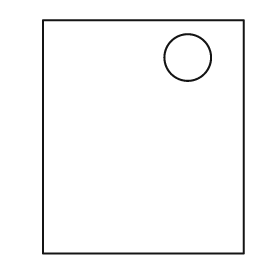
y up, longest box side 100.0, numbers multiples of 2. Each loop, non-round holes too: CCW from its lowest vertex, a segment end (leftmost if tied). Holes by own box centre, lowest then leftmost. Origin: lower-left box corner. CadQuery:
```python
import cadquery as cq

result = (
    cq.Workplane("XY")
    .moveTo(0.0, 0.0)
    .lineTo(86.0, 0.0)
    .lineTo(86.0, 100.0)
    .lineTo(0.0, 100.0)
    .close()
    .moveTo(62.0, 84.0)
    .circle(10.0)
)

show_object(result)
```